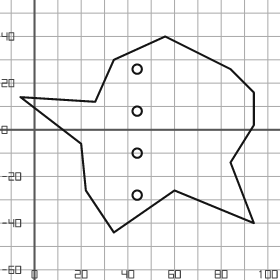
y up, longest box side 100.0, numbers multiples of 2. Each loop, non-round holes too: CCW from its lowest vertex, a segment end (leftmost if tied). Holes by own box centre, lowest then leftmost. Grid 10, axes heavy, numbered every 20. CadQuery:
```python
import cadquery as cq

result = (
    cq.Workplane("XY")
    .moveTo(34.0, -44.0)
    .lineTo(60.0, -26.0)
    .lineTo(94.0, -40.0)
    .lineTo(84.0, -14.0)
    .lineTo(94.0, 2.0)
    .lineTo(94.0, 16.0)
    .lineTo(84.0, 26.0)
    .lineTo(56.0, 40.0)
    .lineTo(34.0, 30.0)
    .lineTo(26.0, 12.0)
    .lineTo(-6.0, 14.0)
    .lineTo(20.0, -6.0)
    .lineTo(22.0, -26.0)
    .close()
    .moveTo(44.0, -28.0)
    .circle(2.0)
    .moveTo(44.0, -10.0)
    .circle(2.0)
    .moveTo(44.0, 8.0)
    .circle(2.0)
    .moveTo(44.0, 26.0)
    .circle(2.0)
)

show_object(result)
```